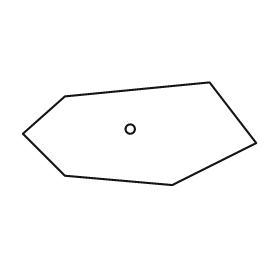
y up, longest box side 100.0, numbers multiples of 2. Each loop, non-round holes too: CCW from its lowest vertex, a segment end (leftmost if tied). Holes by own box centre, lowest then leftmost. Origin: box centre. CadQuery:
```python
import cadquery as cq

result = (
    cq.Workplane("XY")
    .moveTo(14.0, -22.0)
    .lineTo(50.0, -4.0)
    .lineTo(30.0, 22.0)
    .lineTo(-32.0, 16.0)
    .lineTo(-50.0, 0.0)
    .lineTo(-32.0, -18.0)
    .close()
    .moveTo(-4.0, 2.0)
    .circle(2.0)
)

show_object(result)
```